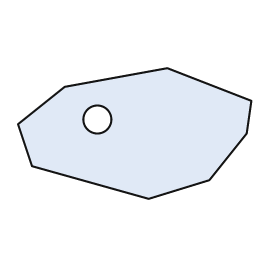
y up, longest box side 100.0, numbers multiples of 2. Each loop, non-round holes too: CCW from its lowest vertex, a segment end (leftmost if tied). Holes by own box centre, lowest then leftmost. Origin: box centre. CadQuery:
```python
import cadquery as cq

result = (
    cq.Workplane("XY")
    .moveTo(6.0, -28.0)
    .lineTo(32.0, -20.0)
    .lineTo(48.0, 0.0)
    .lineTo(50.0, 14.0)
    .lineTo(14.0, 28.0)
    .lineTo(-30.0, 20.0)
    .lineTo(-50.0, 4.0)
    .lineTo(-44.0, -14.0)
    .close()
    .moveTo(-16.0, 6.0)
    .circle(6.0)
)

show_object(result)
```